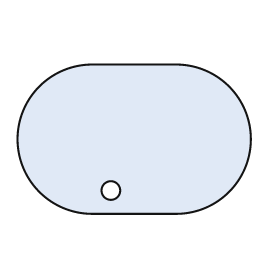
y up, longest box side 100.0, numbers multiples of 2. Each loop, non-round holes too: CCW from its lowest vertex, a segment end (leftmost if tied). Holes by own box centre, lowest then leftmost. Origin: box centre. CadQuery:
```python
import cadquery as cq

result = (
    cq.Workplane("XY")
    .moveTo(-18.0, -32.0)
    .lineTo(18.0, -32.0)
    .threePointArc((50.0, 0.0), (18.0, 32.0))
    .lineTo(-18.0, 32.0)
    .threePointArc((-50.0, 0.0), (-18.0, -32.0))
    .close()
    .moveTo(-10.0, -22.0)
    .circle(4.0)
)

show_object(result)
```